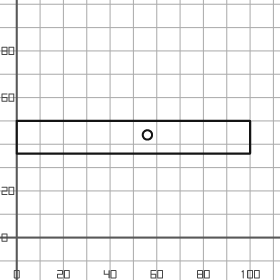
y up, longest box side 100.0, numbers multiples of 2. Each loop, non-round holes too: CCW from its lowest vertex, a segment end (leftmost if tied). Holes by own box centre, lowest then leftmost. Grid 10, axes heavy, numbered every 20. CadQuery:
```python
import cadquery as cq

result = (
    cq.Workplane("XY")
    .moveTo(0.0, 36.0)
    .lineTo(100.0, 36.0)
    .lineTo(100.0, 50.0)
    .lineTo(0.0, 50.0)
    .close()
    .moveTo(56.0, 44.0)
    .circle(2.0)
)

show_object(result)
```